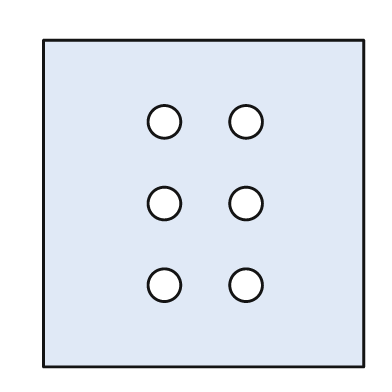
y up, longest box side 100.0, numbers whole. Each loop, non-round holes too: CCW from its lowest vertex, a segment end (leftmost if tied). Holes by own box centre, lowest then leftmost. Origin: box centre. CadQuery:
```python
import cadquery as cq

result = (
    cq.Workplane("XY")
    .moveTo(-49.0, -50.0)
    .lineTo(49.0, -50.0)
    .lineTo(49.0, 50.0)
    .lineTo(-49.0, 50.0)
    .close()
    .moveTo(-12.0, -25.0)
    .circle(5.0)
    .moveTo(13.0, -25.0)
    .circle(5.0)
    .moveTo(-12.0, 0.0)
    .circle(5.0)
    .moveTo(13.0, 0.0)
    .circle(5.0)
    .moveTo(-12.0, 25.0)
    .circle(5.0)
    .moveTo(13.0, 25.0)
    .circle(5.0)
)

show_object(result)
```